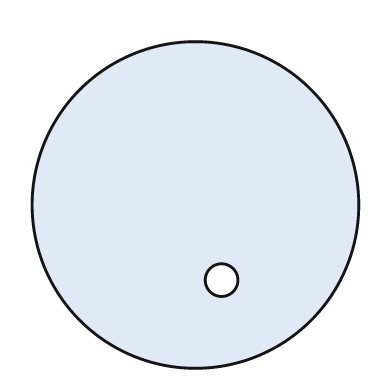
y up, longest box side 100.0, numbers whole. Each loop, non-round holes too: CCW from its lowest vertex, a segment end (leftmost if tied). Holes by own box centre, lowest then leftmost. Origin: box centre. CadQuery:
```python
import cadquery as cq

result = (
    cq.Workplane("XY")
    .moveTo(0.0, 0.0)
    .circle(50.0)
    .moveTo(8.0, -23.0)
    .circle(5.0)
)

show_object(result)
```